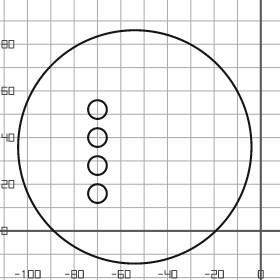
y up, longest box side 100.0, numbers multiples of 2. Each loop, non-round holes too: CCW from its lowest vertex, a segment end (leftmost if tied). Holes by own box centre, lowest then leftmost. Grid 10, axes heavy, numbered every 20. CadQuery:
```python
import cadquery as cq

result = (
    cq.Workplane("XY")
    .moveTo(-54.0, 36.0)
    .circle(50.0)
    .moveTo(-70.0, 16.0)
    .circle(4.0)
    .moveTo(-70.0, 28.0)
    .circle(4.0)
    .moveTo(-70.0, 40.0)
    .circle(4.0)
    .moveTo(-70.0, 52.0)
    .circle(4.0)
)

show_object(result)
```